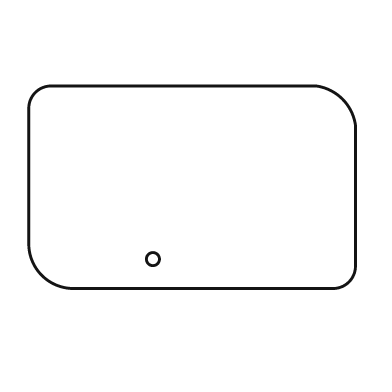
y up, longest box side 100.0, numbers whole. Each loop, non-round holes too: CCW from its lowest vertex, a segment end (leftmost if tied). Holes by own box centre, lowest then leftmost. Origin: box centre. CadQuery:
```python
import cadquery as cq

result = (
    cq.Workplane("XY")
    .moveTo(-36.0, -31.0)
    .lineTo(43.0, -31.0)
    .threePointArc((48.0, -29.0), (50.0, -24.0))
    .lineTo(50.0, 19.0)
    .threePointArc((46.0, 27.0), (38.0, 31.0))
    .lineTo(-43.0, 31.0)
    .threePointArc((-48.0, 29.0), (-50.0, 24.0))
    .lineTo(-50.0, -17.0)
    .threePointArc((-46.0, -27.0), (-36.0, -31.0))
    .close()
    .moveTo(-12.0, -22.0)
    .circle(2.0)
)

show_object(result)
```